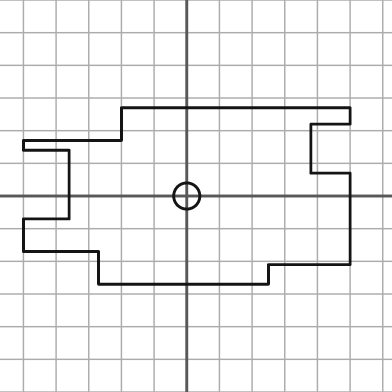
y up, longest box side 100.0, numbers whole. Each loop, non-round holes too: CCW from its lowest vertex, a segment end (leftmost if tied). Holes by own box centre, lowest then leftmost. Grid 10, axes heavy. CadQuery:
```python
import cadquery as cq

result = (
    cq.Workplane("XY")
    .moveTo(-27.0, -27.0)
    .lineTo(25.0, -27.0)
    .lineTo(25.0, -21.0)
    .lineTo(50.0, -21.0)
    .lineTo(50.0, 7.0)
    .lineTo(38.0, 7.0)
    .lineTo(38.0, 22.0)
    .lineTo(50.0, 22.0)
    .lineTo(50.0, 27.0)
    .lineTo(-20.0, 27.0)
    .lineTo(-20.0, 17.0)
    .lineTo(-50.0, 17.0)
    .lineTo(-50.0, 14.0)
    .lineTo(-36.0, 14.0)
    .lineTo(-36.0, -7.0)
    .lineTo(-50.0, -7.0)
    .lineTo(-50.0, -17.0)
    .lineTo(-27.0, -17.0)
    .close()
    .moveTo(0.0, 0.0)
    .circle(4.0)
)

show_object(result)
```